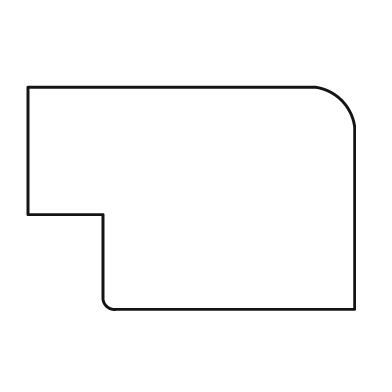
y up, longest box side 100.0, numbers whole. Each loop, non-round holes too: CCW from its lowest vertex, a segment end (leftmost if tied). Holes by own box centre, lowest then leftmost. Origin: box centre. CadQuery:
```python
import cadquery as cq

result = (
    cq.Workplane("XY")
    .moveTo(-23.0, -34.0)
    .lineTo(50.0, -34.0)
    .lineTo(50.0, 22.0)
    .threePointArc((46.0, 30.0), (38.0, 34.0))
    .lineTo(-50.0, 34.0)
    .lineTo(-50.0, -5.0)
    .lineTo(-27.0, -5.0)
    .lineTo(-27.0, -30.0)
    .threePointArc((-26.0, -33.0), (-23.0, -34.0))
    .close()
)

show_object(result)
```